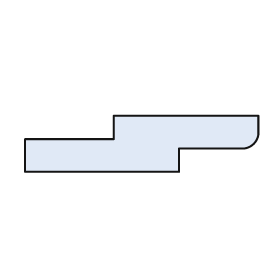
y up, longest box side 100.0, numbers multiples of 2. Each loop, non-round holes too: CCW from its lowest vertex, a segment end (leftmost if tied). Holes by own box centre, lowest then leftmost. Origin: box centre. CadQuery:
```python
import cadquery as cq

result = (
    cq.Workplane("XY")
    .moveTo(-50.0, -12.0)
    .lineTo(16.0, -12.0)
    .lineTo(16.0, -2.0)
    .lineTo(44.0, -2.0)
    .threePointArc((48.0, 0.0), (50.0, 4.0))
    .lineTo(50.0, 12.0)
    .lineTo(-12.0, 12.0)
    .lineTo(-12.0, 2.0)
    .lineTo(-50.0, 2.0)
    .close()
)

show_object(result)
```